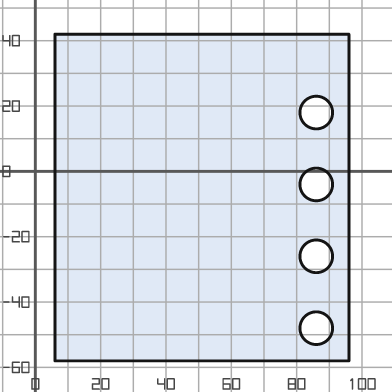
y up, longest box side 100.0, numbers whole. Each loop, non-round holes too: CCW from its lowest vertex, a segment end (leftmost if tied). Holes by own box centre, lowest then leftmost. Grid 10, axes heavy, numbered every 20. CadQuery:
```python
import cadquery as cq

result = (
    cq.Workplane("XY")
    .moveTo(6.0, -58.0)
    .lineTo(96.0, -58.0)
    .lineTo(96.0, 42.0)
    .lineTo(6.0, 42.0)
    .close()
    .moveTo(86.0, -48.0)
    .circle(5.0)
    .moveTo(86.0, -26.0)
    .circle(5.0)
    .moveTo(86.0, -4.0)
    .circle(5.0)
    .moveTo(86.0, 18.0)
    .circle(5.0)
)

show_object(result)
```